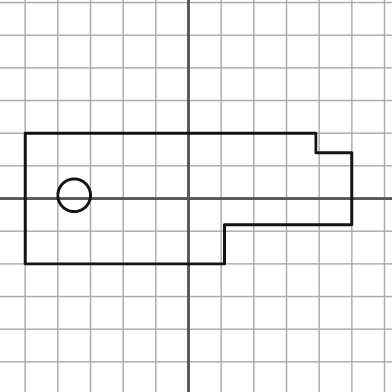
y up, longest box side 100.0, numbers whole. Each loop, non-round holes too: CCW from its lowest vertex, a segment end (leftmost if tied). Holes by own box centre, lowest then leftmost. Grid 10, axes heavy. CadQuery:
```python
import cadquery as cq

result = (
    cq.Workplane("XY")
    .moveTo(-50.0, -20.0)
    .lineTo(11.0, -20.0)
    .lineTo(11.0, -8.0)
    .lineTo(50.0, -8.0)
    .lineTo(50.0, 14.0)
    .lineTo(39.0, 14.0)
    .lineTo(39.0, 20.0)
    .lineTo(-50.0, 20.0)
    .close()
    .moveTo(-35.0, 1.0)
    .circle(5.0)
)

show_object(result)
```